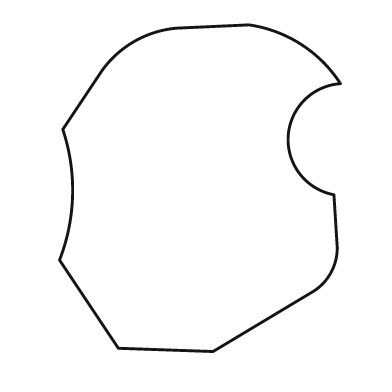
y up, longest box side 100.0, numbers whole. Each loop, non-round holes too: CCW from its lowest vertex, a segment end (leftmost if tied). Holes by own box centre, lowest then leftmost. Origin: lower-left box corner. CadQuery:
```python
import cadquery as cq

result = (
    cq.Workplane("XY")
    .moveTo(47.0, 0.0)
    .lineTo(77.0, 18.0)
    .threePointArc((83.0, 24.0), (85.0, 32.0))
    .lineTo(84.0, 48.0)
    .threePointArc((70.0, 66.0), (86.0, 82.0))
    .threePointArc((74.0, 94.0), (58.0, 100.0))
    .lineTo(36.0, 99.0)
    .threePointArc((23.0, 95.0), (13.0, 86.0))
    .lineTo(1.0, 68.0)
    .threePointArc((4.0, 48.0), (0.0, 28.0))
    .lineTo(18.0, 1.0)
    .close()
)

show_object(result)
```